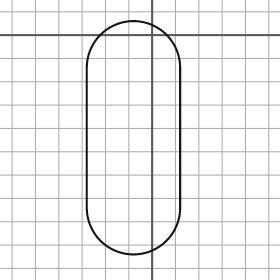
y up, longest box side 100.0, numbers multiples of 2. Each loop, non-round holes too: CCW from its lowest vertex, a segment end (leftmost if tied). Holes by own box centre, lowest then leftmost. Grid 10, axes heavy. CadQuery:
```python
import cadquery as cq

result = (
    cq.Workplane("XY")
    .moveTo(-28.0, -74.0)
    .threePointArc((-8.0, -94.0), (12.0, -74.0))
    .lineTo(12.0, -14.0)
    .threePointArc((-8.0, 6.0), (-28.0, -14.0))
    .close()
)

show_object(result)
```